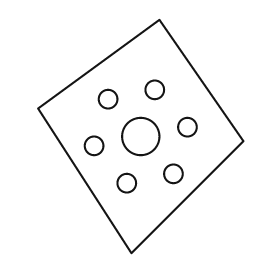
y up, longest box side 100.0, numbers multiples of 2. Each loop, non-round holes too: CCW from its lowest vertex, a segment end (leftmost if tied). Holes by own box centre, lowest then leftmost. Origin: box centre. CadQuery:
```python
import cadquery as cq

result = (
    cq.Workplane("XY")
    .moveTo(-4.0, -50.0)
    .lineTo(44.0, -2.0)
    .lineTo(8.0, 50.0)
    .lineTo(-44.0, 12.0)
    .close()
    .moveTo(-6.0, -20.0)
    .circle(4.0)
    .moveTo(14.0, -16.0)
    .circle(4.0)
    .moveTo(-20.0, -4.0)
    .circle(4.0)
    .moveTo(0.0, 0.0)
    .circle(8.0)
    .moveTo(20.0, 4.0)
    .circle(4.0)
    .moveTo(-14.0, 16.0)
    .circle(4.0)
    .moveTo(6.0, 20.0)
    .circle(4.0)
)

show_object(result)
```